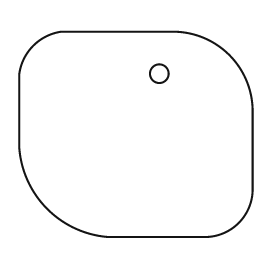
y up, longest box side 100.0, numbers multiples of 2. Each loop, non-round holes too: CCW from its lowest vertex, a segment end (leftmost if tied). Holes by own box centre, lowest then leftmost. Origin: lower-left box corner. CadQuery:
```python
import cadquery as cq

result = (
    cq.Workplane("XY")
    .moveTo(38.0, 0.0)
    .lineTo(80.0, 0.0)
    .threePointArc((94.0, 6.0), (100.0, 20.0))
    .lineTo(100.0, 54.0)
    .threePointArc((90.0, 78.0), (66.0, 88.0))
    .lineTo(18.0, 88.0)
    .threePointArc((6.0, 82.0), (0.0, 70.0))
    .lineTo(0.0, 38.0)
    .threePointArc((12.0, 12.0), (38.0, 0.0))
    .close()
    .moveTo(60.0, 70.0)
    .circle(4.0)
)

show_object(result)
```